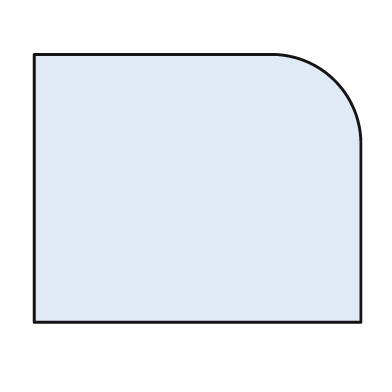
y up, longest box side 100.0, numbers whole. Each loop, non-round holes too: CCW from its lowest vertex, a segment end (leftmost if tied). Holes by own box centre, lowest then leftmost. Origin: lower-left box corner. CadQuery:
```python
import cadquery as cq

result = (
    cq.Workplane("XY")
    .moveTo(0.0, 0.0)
    .lineTo(100.0, 0.0)
    .lineTo(100.0, 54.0)
    .threePointArc((92.0, 74.0), (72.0, 82.0))
    .lineTo(0.0, 82.0)
    .close()
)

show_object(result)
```